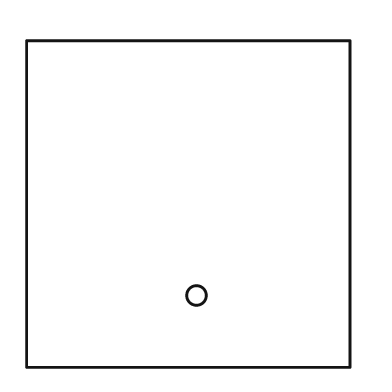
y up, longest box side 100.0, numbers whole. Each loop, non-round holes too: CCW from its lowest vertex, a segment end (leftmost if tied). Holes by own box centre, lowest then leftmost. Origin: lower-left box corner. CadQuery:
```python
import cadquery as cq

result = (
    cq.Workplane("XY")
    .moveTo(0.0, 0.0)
    .lineTo(99.0, 0.0)
    .lineTo(99.0, 100.0)
    .lineTo(0.0, 100.0)
    .close()
    .moveTo(52.0, 22.0)
    .circle(3.0)
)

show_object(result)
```